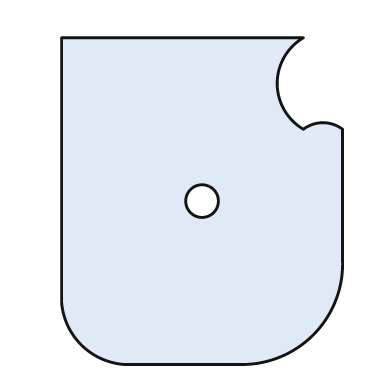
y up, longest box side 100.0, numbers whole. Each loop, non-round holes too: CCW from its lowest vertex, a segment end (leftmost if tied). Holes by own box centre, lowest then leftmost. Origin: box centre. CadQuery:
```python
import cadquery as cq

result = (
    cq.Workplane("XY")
    .moveTo(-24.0, -50.0)
    .lineTo(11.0, -50.0)
    .threePointArc((34.0, -41.0), (43.0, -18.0))
    .lineTo(43.0, 22.0)
    .threePointArc((37.0, 24.0), (31.0, 22.0))
    .threePointArc((23.0, 36.0), (31.0, 50.0))
    .lineTo(-43.0, 50.0)
    .lineTo(-43.0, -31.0)
    .threePointArc((-37.0, -44.0), (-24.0, -50.0))
    .close()
    .moveTo(0.0, 0.0)
    .circle(5.0)
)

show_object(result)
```